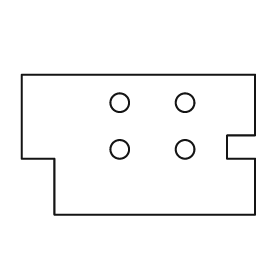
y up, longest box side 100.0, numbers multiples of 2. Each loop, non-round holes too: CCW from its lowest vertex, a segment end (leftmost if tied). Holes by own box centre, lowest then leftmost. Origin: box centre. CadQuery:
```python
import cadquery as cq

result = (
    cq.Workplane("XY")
    .moveTo(-36.0, -30.0)
    .lineTo(50.0, -30.0)
    .lineTo(50.0, -6.0)
    .lineTo(38.0, -6.0)
    .lineTo(38.0, 4.0)
    .lineTo(50.0, 4.0)
    .lineTo(50.0, 30.0)
    .lineTo(-50.0, 30.0)
    .lineTo(-50.0, -6.0)
    .lineTo(-36.0, -6.0)
    .close()
    .moveTo(-8.0, -2.0)
    .circle(4.0)
    .moveTo(20.0, -2.0)
    .circle(4.0)
    .moveTo(-8.0, 18.0)
    .circle(4.0)
    .moveTo(20.0, 18.0)
    .circle(4.0)
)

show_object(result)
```